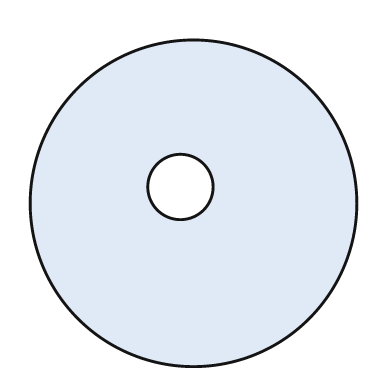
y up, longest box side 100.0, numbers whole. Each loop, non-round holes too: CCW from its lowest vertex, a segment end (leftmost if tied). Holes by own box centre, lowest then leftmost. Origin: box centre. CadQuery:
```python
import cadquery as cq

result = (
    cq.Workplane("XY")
    .moveTo(0.0, 0.0)
    .circle(50.0)
    .moveTo(-4.0, 5.0)
    .circle(10.0)
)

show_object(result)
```